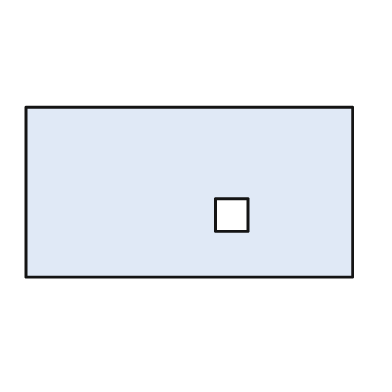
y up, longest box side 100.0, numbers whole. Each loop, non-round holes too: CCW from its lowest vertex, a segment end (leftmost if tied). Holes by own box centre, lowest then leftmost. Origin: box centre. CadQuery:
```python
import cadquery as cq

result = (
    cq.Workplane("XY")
    .moveTo(-50.0, -26.0)
    .lineTo(50.0, -26.0)
    .lineTo(50.0, 26.0)
    .lineTo(-50.0, 26.0)
    .close()
    .moveTo(8.0, -12.0)
    .lineTo(18.0, -12.0)
    .lineTo(18.0, -2.0)
    .lineTo(8.0, -2.0)
    .close()
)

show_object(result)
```